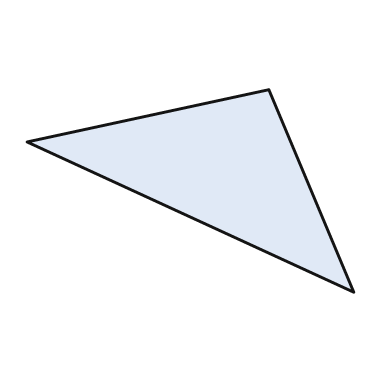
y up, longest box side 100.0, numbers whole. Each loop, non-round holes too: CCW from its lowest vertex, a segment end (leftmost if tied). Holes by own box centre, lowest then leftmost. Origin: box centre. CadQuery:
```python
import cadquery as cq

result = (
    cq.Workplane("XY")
    .moveTo(50.0, -31.0)
    .lineTo(24.0, 31.0)
    .lineTo(-50.0, 15.0)
    .close()
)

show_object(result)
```